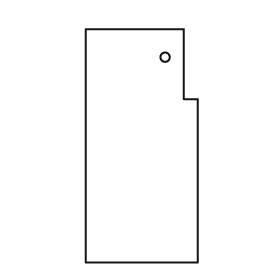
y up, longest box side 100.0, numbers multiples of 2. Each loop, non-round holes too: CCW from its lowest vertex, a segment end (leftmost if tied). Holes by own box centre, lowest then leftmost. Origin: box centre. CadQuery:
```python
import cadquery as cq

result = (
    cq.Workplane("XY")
    .moveTo(-24.0, -50.0)
    .lineTo(24.0, -50.0)
    .lineTo(24.0, 20.0)
    .lineTo(18.0, 20.0)
    .lineTo(18.0, 50.0)
    .lineTo(-24.0, 50.0)
    .close()
    .moveTo(10.0, 38.0)
    .circle(2.0)
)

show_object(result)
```